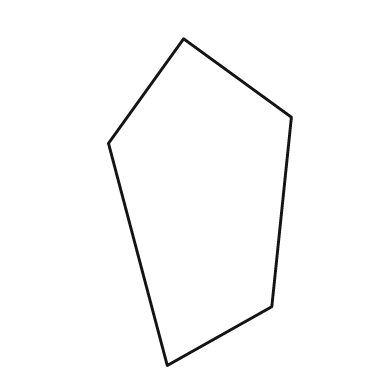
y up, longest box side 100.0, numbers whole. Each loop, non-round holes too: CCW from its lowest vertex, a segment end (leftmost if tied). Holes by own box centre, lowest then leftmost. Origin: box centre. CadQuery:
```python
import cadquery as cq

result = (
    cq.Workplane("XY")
    .moveTo(-10.0, -50.0)
    .lineTo(22.0, -32.0)
    .lineTo(28.0, 26.0)
    .lineTo(-5.0, 50.0)
    .lineTo(-28.0, 18.0)
    .close()
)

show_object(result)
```